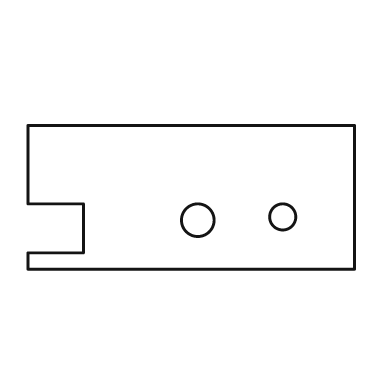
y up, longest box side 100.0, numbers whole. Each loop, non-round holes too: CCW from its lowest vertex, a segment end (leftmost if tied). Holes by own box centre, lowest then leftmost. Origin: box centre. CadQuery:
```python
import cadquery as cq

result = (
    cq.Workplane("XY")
    .moveTo(-50.0, -22.0)
    .lineTo(50.0, -22.0)
    .lineTo(50.0, 22.0)
    .lineTo(-50.0, 22.0)
    .lineTo(-50.0, -2.0)
    .lineTo(-33.0, -2.0)
    .lineTo(-33.0, -17.0)
    .lineTo(-50.0, -17.0)
    .close()
    .moveTo(2.0, -7.0)
    .circle(5.0)
    .moveTo(28.0, -6.0)
    .circle(4.0)
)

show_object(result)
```